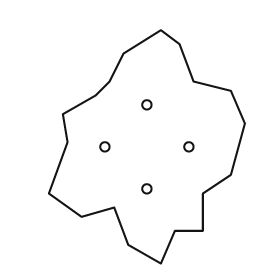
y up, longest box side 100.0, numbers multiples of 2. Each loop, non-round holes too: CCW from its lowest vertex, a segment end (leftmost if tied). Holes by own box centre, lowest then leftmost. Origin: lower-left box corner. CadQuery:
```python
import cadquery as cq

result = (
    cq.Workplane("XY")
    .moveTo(48.0, 0.0)
    .lineTo(54.0, 14.0)
    .lineTo(66.0, 14.0)
    .lineTo(66.0, 30.0)
    .lineTo(78.0, 38.0)
    .lineTo(84.0, 60.0)
    .lineTo(78.0, 74.0)
    .lineTo(62.0, 78.0)
    .lineTo(56.0, 94.0)
    .lineTo(48.0, 100.0)
    .lineTo(32.0, 90.0)
    .lineTo(26.0, 78.0)
    .lineTo(20.0, 72.0)
    .lineTo(6.0, 64.0)
    .lineTo(8.0, 52.0)
    .lineTo(0.0, 30.0)
    .lineTo(14.0, 20.0)
    .lineTo(28.0, 24.0)
    .lineTo(34.0, 8.0)
    .close()
    .moveTo(42.0, 32.0)
    .circle(2.0)
    .moveTo(24.0, 50.0)
    .circle(2.0)
    .moveTo(60.0, 50.0)
    .circle(2.0)
    .moveTo(42.0, 68.0)
    .circle(2.0)
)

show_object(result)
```